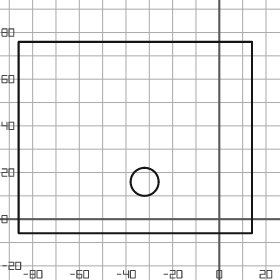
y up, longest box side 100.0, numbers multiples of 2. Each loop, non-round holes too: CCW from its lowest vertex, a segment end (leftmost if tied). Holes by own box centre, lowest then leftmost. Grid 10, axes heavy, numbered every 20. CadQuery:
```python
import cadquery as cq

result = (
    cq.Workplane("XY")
    .moveTo(-86.0, -6.0)
    .lineTo(14.0, -6.0)
    .lineTo(14.0, 76.0)
    .lineTo(-86.0, 76.0)
    .close()
    .moveTo(-32.0, 16.0)
    .circle(6.0)
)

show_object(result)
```